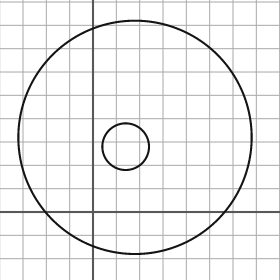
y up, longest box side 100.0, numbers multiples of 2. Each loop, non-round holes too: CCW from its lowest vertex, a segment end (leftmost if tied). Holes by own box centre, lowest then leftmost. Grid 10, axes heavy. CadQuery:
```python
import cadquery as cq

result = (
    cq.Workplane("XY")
    .moveTo(18.0, 32.0)
    .circle(50.0)
    .moveTo(14.0, 28.0)
    .circle(10.0)
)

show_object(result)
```